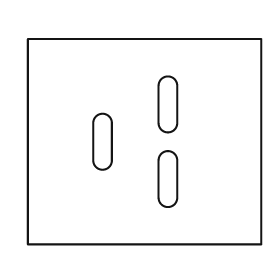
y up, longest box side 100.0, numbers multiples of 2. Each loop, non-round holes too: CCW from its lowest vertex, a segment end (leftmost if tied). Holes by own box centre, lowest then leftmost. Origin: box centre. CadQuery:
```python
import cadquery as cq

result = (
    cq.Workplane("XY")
    .moveTo(-50.0, -44.0)
    .lineTo(50.0, -44.0)
    .lineTo(50.0, 44.0)
    .lineTo(-50.0, 44.0)
    .close()
    .moveTo(6.0, -24.0)
    .threePointArc((10.0, -28.0), (14.0, -24.0))
    .lineTo(14.0, -8.0)
    .threePointArc((10.0, -4.0), (6.0, -8.0))
    .close()
    .moveTo(-22.0, -8.0)
    .threePointArc((-18.0, -12.0), (-14.0, -8.0))
    .lineTo(-14.0, 8.0)
    .threePointArc((-18.0, 12.0), (-22.0, 8.0))
    .close()
    .moveTo(6.0, 8.0)
    .threePointArc((10.0, 4.0), (14.0, 8.0))
    .lineTo(14.0, 24.0)
    .threePointArc((10.0, 28.0), (6.0, 24.0))
    .close()
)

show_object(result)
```